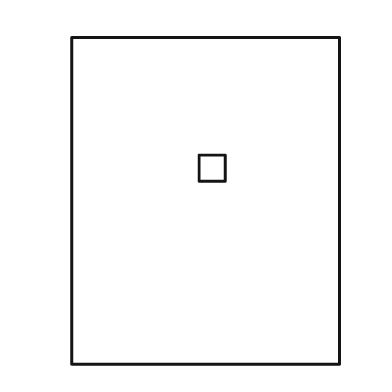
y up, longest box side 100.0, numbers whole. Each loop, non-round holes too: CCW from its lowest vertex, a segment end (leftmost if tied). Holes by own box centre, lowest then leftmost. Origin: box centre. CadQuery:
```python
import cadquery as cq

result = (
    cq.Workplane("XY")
    .moveTo(-41.0, -50.0)
    .lineTo(41.0, -50.0)
    .lineTo(41.0, 50.0)
    .lineTo(-41.0, 50.0)
    .close()
    .moveTo(-2.0, 6.0)
    .lineTo(6.0, 6.0)
    .lineTo(6.0, 14.0)
    .lineTo(-2.0, 14.0)
    .close()
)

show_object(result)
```